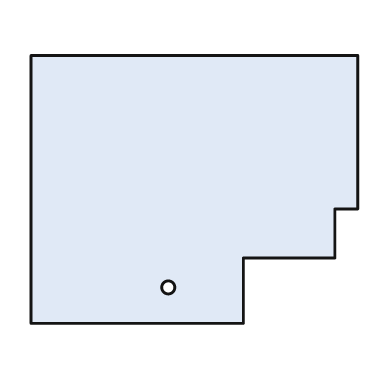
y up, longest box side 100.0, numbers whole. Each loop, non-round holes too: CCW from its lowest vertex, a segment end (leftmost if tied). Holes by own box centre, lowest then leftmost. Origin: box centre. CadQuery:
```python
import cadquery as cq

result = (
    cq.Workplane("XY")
    .moveTo(-50.0, -41.0)
    .lineTo(15.0, -41.0)
    .lineTo(15.0, -21.0)
    .lineTo(43.0, -21.0)
    .lineTo(43.0, -6.0)
    .lineTo(50.0, -6.0)
    .lineTo(50.0, 41.0)
    .lineTo(-50.0, 41.0)
    .close()
    .moveTo(-8.0, -30.0)
    .circle(2.0)
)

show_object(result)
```